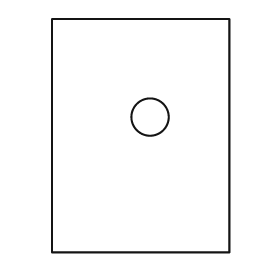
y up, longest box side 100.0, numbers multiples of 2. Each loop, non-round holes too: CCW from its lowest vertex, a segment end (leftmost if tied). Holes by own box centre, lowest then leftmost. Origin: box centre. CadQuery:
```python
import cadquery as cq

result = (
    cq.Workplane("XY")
    .moveTo(-38.0, -50.0)
    .lineTo(38.0, -50.0)
    .lineTo(38.0, 50.0)
    .lineTo(-38.0, 50.0)
    .close()
    .moveTo(4.0, 8.0)
    .circle(8.0)
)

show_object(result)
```